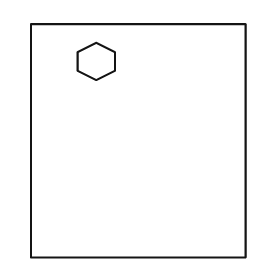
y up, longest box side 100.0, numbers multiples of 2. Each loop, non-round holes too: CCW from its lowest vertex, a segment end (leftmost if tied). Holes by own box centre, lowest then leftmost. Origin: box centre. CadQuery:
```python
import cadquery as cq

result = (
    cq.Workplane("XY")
    .moveTo(-46.0, -50.0)
    .lineTo(46.0, -50.0)
    .lineTo(46.0, 50.0)
    .lineTo(-46.0, 50.0)
    .close()
    .moveTo(-18.0, 26.0)
    .lineTo(-10.0, 30.0)
    .lineTo(-10.0, 38.0)
    .lineTo(-18.0, 42.0)
    .lineTo(-26.0, 38.0)
    .lineTo(-26.0, 30.0)
    .close()
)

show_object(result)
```